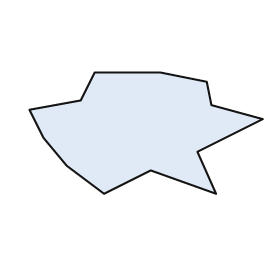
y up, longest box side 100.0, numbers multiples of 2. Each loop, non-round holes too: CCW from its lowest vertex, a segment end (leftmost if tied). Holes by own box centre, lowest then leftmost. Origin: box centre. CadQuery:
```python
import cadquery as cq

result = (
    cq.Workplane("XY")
    .moveTo(-18.0, -26.0)
    .lineTo(2.0, -16.0)
    .lineTo(30.0, -26.0)
    .lineTo(22.0, -8.0)
    .lineTo(50.0, 6.0)
    .lineTo(28.0, 12.0)
    .lineTo(26.0, 22.0)
    .lineTo(6.0, 26.0)
    .lineTo(-22.0, 26.0)
    .lineTo(-28.0, 14.0)
    .lineTo(-50.0, 10.0)
    .lineTo(-44.0, -2.0)
    .lineTo(-34.0, -14.0)
    .close()
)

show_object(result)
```